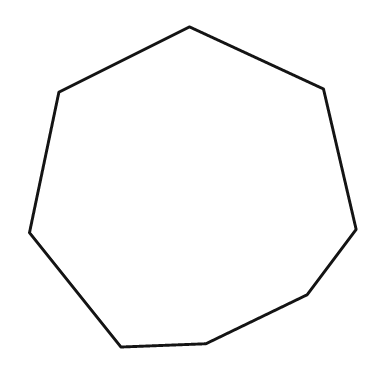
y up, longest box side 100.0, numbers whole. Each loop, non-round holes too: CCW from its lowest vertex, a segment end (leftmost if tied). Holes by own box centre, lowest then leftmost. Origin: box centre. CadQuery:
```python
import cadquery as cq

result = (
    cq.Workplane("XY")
    .moveTo(-22.0, -49.0)
    .lineTo(4.0, -48.0)
    .lineTo(35.0, -33.0)
    .lineTo(50.0, -13.0)
    .lineTo(40.0, 30.0)
    .lineTo(-1.0, 49.0)
    .lineTo(-41.0, 29.0)
    .lineTo(-50.0, -14.0)
    .close()
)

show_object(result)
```